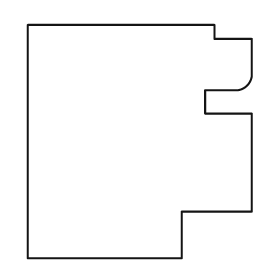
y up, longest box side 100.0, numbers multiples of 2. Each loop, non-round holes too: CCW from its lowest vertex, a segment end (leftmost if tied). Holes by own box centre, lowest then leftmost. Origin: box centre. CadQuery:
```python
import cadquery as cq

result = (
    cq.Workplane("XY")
    .moveTo(-48.0, -50.0)
    .lineTo(18.0, -50.0)
    .lineTo(18.0, -30.0)
    .lineTo(48.0, -30.0)
    .lineTo(48.0, 12.0)
    .lineTo(28.0, 12.0)
    .lineTo(28.0, 22.0)
    .lineTo(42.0, 22.0)
    .threePointArc((46.0, 24.0), (48.0, 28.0))
    .lineTo(48.0, 44.0)
    .lineTo(32.0, 44.0)
    .lineTo(32.0, 50.0)
    .lineTo(-48.0, 50.0)
    .close()
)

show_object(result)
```